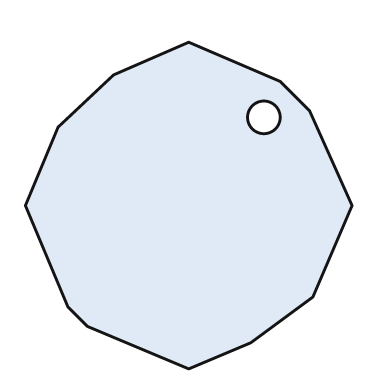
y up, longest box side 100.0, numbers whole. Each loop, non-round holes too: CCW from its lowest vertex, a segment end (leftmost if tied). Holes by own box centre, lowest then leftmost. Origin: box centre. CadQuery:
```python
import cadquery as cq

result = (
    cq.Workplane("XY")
    .moveTo(0.0, -50.0)
    .lineTo(19.0, -42.0)
    .lineTo(38.0, -28.0)
    .lineTo(50.0, 0.0)
    .lineTo(37.0, 29.0)
    .lineTo(28.0, 38.0)
    .lineTo(0.0, 50.0)
    .lineTo(-23.0, 40.0)
    .lineTo(-40.0, 24.0)
    .lineTo(-50.0, 0.0)
    .lineTo(-37.0, -31.0)
    .lineTo(-31.0, -37.0)
    .close()
    .moveTo(23.0, 27.0)
    .circle(5.0)
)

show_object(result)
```